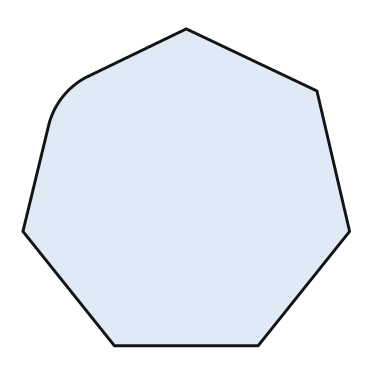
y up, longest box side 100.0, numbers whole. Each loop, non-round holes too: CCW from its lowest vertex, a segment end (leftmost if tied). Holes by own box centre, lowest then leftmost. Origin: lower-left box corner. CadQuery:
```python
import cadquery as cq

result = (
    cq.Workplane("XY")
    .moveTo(28.0, 0.0)
    .lineTo(72.0, 0.0)
    .lineTo(100.0, 35.0)
    .lineTo(90.0, 78.0)
    .lineTo(50.0, 97.0)
    .lineTo(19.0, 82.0)
    .threePointArc((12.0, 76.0), (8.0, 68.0))
    .lineTo(0.0, 35.0)
    .close()
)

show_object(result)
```